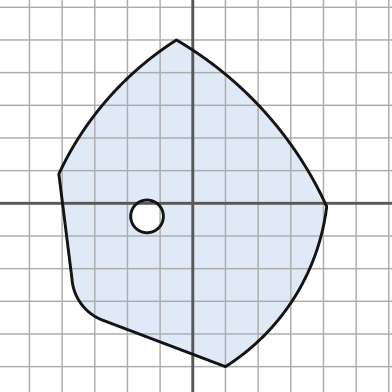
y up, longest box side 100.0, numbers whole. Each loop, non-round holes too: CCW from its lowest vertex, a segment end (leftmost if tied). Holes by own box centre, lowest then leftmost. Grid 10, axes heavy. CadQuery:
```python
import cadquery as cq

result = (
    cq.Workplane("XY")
    .moveTo(10.0, -50.0)
    .threePointArc((31.0, -29.0), (41.0, -1.0))
    .threePointArc((22.0, 28.0), (-5.0, 50.0))
    .threePointArc((-26.0, 32.0), (-41.0, 9.0))
    .lineTo(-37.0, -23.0)
    .threePointArc((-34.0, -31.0), (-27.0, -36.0))
    .close()
    .moveTo(-14.0, -4.0)
    .circle(5.0)
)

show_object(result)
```